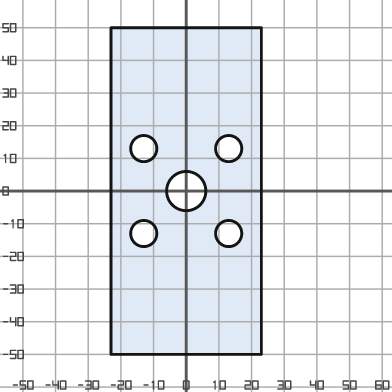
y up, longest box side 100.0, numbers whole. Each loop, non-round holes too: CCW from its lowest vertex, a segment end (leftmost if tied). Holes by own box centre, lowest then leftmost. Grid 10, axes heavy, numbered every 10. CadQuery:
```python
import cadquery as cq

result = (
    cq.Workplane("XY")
    .moveTo(-23.0, -50.0)
    .lineTo(23.0, -50.0)
    .lineTo(23.0, 50.0)
    .lineTo(-23.0, 50.0)
    .close()
    .moveTo(-13.0, -13.0)
    .circle(4.0)
    .moveTo(13.0, -13.0)
    .circle(4.0)
    .moveTo(0.0, 0.0)
    .circle(6.0)
    .moveTo(-13.0, 13.0)
    .circle(4.0)
    .moveTo(13.0, 13.0)
    .circle(4.0)
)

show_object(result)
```